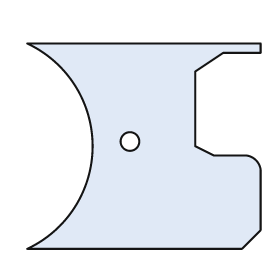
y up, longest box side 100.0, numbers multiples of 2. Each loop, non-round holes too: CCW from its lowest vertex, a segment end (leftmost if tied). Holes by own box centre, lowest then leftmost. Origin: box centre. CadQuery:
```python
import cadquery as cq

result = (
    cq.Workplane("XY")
    .moveTo(-50.0, -44.0)
    .lineTo(42.0, -44.0)
    .lineTo(50.0, -36.0)
    .lineTo(50.0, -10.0)
    .threePointArc((48.0, -6.0), (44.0, -4.0))
    .lineTo(30.0, -4.0)
    .lineTo(22.0, 0.0)
    .lineTo(22.0, 32.0)
    .lineTo(34.0, 40.0)
    .lineTo(50.0, 40.0)
    .lineTo(50.0, 44.0)
    .lineTo(-50.0, 44.0)
    .threePointArc((-22.0, 0.0), (-50.0, -44.0))
    .close()
    .moveTo(-6.0, 2.0)
    .circle(4.0)
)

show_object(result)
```